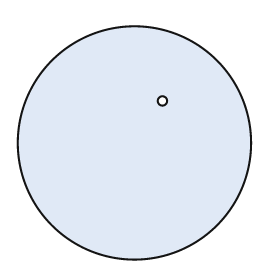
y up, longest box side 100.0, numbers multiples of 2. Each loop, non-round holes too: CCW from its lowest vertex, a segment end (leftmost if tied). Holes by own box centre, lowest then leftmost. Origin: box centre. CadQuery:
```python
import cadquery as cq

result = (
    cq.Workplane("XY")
    .moveTo(0.0, 0.0)
    .circle(50.0)
    .moveTo(12.0, 18.0)
    .circle(2.0)
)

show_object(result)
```